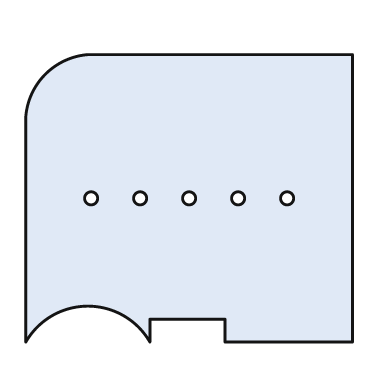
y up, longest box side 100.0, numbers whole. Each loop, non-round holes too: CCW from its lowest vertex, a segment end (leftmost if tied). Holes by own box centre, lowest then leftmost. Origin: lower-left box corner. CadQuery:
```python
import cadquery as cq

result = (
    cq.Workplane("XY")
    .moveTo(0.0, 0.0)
    .threePointArc((19.0, 11.0), (38.0, 0.0))
    .lineTo(38.0, 7.0)
    .lineTo(61.0, 7.0)
    .lineTo(61.0, 0.0)
    .lineTo(100.0, 0.0)
    .lineTo(100.0, 88.0)
    .lineTo(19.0, 88.0)
    .threePointArc((6.0, 82.0), (0.0, 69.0))
    .close()
    .moveTo(20.0, 44.0)
    .circle(2.0)
    .moveTo(35.0, 44.0)
    .circle(2.0)
    .moveTo(50.0, 44.0)
    .circle(2.0)
    .moveTo(65.0, 44.0)
    .circle(2.0)
    .moveTo(80.0, 44.0)
    .circle(2.0)
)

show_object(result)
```